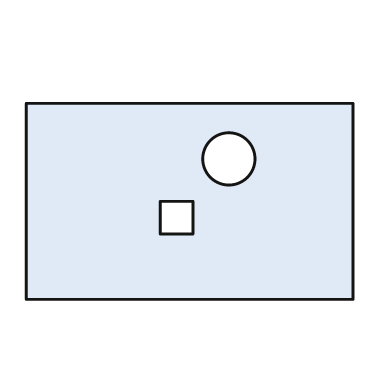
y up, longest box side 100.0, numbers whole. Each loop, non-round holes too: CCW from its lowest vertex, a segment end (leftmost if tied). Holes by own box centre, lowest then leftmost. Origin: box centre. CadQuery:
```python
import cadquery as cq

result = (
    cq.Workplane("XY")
    .moveTo(-50.0, -30.0)
    .lineTo(50.0, -30.0)
    .lineTo(50.0, 30.0)
    .lineTo(-50.0, 30.0)
    .close()
    .moveTo(-9.0, -10.0)
    .lineTo(1.0, -10.0)
    .lineTo(1.0, 0.0)
    .lineTo(-9.0, 0.0)
    .close()
    .moveTo(12.0, 13.0)
    .circle(8.0)
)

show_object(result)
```